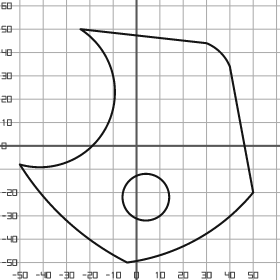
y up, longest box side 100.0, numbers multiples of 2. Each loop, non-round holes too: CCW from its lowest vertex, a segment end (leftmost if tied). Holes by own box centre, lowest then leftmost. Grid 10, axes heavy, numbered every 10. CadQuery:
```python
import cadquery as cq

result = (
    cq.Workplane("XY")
    .moveTo(-4.0, -50.0)
    .threePointArc((26.0, -40.0), (50.0, -20.0))
    .lineTo(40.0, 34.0)
    .threePointArc((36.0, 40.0), (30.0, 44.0))
    .lineTo(-24.0, 50.0)
    .threePointArc((-12.0, 10.0), (-50.0, -8.0))
    .threePointArc((-30.0, -32.0), (-4.0, -50.0))
    .close()
    .moveTo(4.0, -22.0)
    .circle(10.0)
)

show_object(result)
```